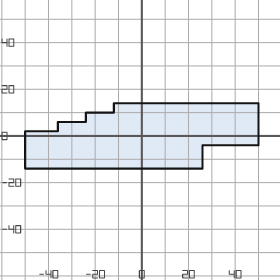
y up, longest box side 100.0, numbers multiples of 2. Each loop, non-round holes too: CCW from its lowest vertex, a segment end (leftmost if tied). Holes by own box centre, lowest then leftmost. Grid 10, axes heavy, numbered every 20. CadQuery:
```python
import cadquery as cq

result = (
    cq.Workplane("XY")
    .moveTo(-50.0, -14.0)
    .lineTo(26.0, -14.0)
    .lineTo(26.0, -4.0)
    .lineTo(50.0, -4.0)
    .lineTo(50.0, 14.0)
    .lineTo(-12.0, 14.0)
    .lineTo(-12.0, 10.0)
    .lineTo(-24.0, 10.0)
    .lineTo(-24.0, 6.0)
    .lineTo(-36.0, 6.0)
    .lineTo(-36.0, 2.0)
    .lineTo(-50.0, 2.0)
    .close()
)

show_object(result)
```